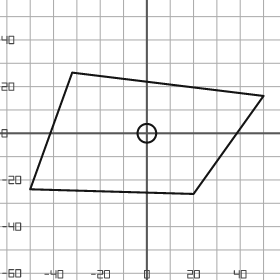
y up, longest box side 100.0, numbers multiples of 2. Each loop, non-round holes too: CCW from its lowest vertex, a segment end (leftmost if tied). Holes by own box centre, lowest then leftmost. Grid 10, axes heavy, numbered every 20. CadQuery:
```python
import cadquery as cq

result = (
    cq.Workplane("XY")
    .moveTo(20.0, -26.0)
    .lineTo(50.0, 16.0)
    .lineTo(-32.0, 26.0)
    .lineTo(-50.0, -24.0)
    .close()
    .moveTo(0.0, 0.0)
    .circle(4.0)
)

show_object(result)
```